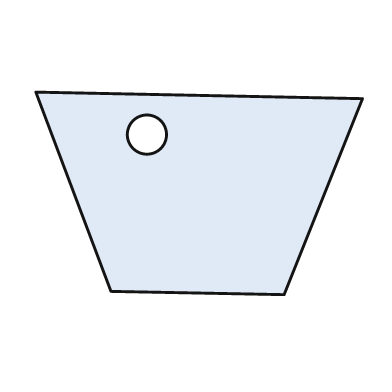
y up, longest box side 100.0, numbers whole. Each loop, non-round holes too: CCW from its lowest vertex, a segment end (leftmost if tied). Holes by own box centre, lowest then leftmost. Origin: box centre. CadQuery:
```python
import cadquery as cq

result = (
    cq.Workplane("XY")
    .moveTo(26.0, -31.0)
    .lineTo(50.0, 29.0)
    .lineTo(-50.0, 31.0)
    .lineTo(-27.0, -30.0)
    .close()
    .moveTo(-16.0, 18.0)
    .circle(6.0)
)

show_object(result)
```